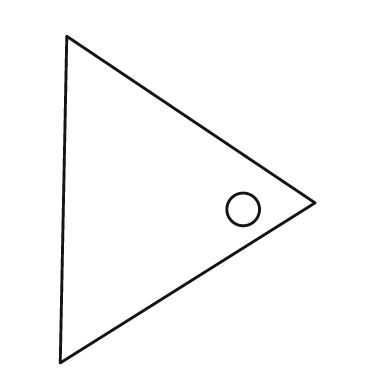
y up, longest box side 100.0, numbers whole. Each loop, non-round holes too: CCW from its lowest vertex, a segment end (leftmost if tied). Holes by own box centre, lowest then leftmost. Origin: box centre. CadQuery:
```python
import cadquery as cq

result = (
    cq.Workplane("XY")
    .moveTo(-39.0, -50.0)
    .lineTo(39.0, -1.0)
    .lineTo(-37.0, 50.0)
    .close()
    .moveTo(17.0, -3.0)
    .circle(5.0)
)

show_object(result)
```